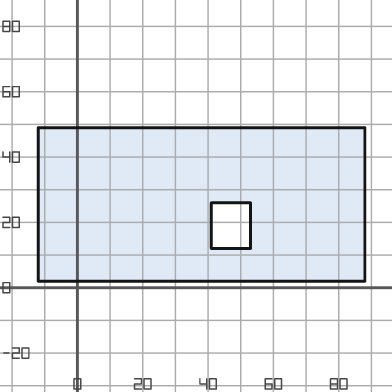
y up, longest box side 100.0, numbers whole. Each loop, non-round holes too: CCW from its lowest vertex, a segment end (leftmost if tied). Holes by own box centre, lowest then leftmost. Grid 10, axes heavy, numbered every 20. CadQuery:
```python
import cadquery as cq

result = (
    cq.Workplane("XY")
    .moveTo(-12.0, 2.0)
    .lineTo(88.0, 2.0)
    .lineTo(88.0, 49.0)
    .lineTo(-12.0, 49.0)
    .close()
    .moveTo(41.0, 12.0)
    .lineTo(53.0, 12.0)
    .lineTo(53.0, 26.0)
    .lineTo(41.0, 26.0)
    .close()
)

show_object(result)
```